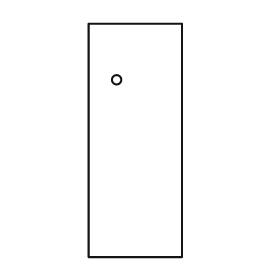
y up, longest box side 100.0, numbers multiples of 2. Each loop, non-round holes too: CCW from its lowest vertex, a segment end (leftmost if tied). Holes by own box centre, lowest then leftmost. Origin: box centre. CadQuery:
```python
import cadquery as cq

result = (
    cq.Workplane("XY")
    .moveTo(-20.0, -50.0)
    .lineTo(20.0, -50.0)
    .lineTo(20.0, 50.0)
    .lineTo(-20.0, 50.0)
    .close()
    .moveTo(-8.0, 26.0)
    .circle(2.0)
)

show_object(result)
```